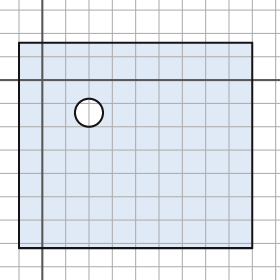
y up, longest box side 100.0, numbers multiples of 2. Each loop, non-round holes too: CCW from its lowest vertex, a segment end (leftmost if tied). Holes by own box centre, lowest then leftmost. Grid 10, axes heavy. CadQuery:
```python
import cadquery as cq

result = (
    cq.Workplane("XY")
    .moveTo(-10.0, -72.0)
    .lineTo(90.0, -72.0)
    .lineTo(90.0, 16.0)
    .lineTo(-10.0, 16.0)
    .close()
    .moveTo(20.0, -14.0)
    .circle(6.0)
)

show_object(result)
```